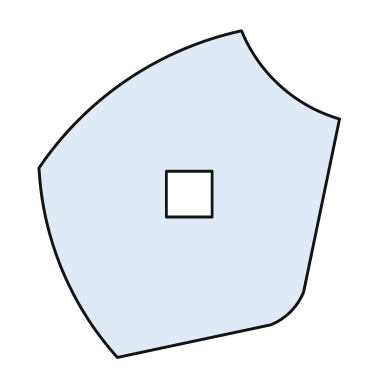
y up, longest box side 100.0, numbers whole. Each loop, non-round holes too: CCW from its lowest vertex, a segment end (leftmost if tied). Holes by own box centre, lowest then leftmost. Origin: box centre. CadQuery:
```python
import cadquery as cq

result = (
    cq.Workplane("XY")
    .moveTo(-22.0, -50.0)
    .lineTo(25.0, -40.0)
    .threePointArc((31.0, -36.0), (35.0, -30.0))
    .lineTo(46.0, 23.0)
    .threePointArc((28.0, 33.0), (16.0, 50.0))
    .threePointArc((-19.0, 35.0), (-46.0, 8.0))
    .threePointArc((-39.0, -23.0), (-22.0, -50.0))
    .close()
    .moveTo(-7.0, -7.0)
    .lineTo(7.0, -7.0)
    .lineTo(7.0, 7.0)
    .lineTo(-7.0, 7.0)
    .close()
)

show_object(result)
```